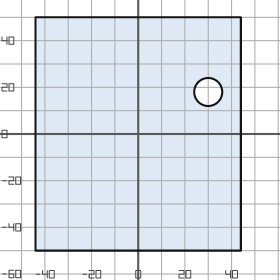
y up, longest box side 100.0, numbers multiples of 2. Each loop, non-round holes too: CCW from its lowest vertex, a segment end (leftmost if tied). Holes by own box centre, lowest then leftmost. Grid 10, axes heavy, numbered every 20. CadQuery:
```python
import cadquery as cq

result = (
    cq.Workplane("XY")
    .moveTo(-44.0, -50.0)
    .lineTo(44.0, -50.0)
    .lineTo(44.0, 50.0)
    .lineTo(-44.0, 50.0)
    .close()
    .moveTo(30.0, 18.0)
    .circle(6.0)
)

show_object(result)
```